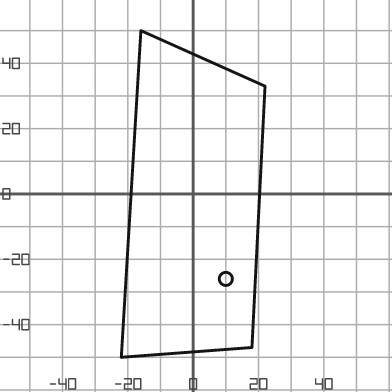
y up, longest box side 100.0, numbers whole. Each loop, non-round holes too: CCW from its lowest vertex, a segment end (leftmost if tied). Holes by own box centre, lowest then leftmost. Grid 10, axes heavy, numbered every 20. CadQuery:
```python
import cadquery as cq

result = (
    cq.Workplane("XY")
    .moveTo(-22.0, -50.0)
    .lineTo(18.0, -47.0)
    .lineTo(22.0, 33.0)
    .lineTo(-16.0, 50.0)
    .close()
    .moveTo(10.0, -26.0)
    .circle(2.0)
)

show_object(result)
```